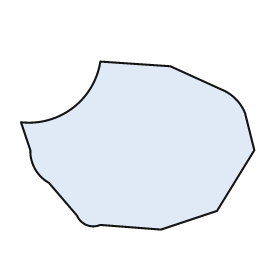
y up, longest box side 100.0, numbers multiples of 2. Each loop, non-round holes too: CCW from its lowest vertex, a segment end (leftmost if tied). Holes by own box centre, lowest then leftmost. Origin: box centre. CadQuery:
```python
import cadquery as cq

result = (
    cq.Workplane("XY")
    .moveTo(10.0, -36.0)
    .lineTo(34.0, -28.0)
    .lineTo(50.0, -2.0)
    .lineTo(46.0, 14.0)
    .threePointArc((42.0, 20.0), (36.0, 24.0))
    .lineTo(14.0, 34.0)
    .lineTo(-16.0, 36.0)
    .threePointArc((-28.0, 16.0), (-50.0, 10.0))
    .lineTo(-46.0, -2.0)
    .threePointArc((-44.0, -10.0), (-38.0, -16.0))
    .lineTo(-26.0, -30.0)
    .threePointArc((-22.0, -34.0), (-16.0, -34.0))
    .close()
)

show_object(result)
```